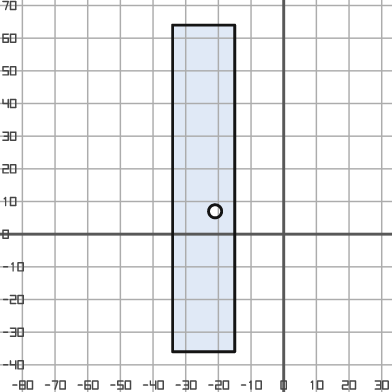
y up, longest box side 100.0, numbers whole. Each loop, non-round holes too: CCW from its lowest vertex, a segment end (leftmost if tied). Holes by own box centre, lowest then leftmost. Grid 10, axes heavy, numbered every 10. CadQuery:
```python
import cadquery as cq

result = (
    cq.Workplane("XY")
    .moveTo(-34.0, -36.0)
    .lineTo(-15.0, -36.0)
    .lineTo(-15.0, 64.0)
    .lineTo(-34.0, 64.0)
    .close()
    .moveTo(-21.0, 7.0)
    .circle(2.0)
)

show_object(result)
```